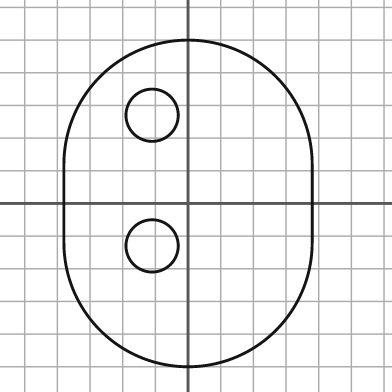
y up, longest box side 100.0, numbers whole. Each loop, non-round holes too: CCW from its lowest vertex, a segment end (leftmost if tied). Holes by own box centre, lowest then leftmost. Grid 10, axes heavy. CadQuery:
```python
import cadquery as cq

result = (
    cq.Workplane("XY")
    .moveTo(-38.0, -12.0)
    .threePointArc((0.0, -50.0), (38.0, -12.0))
    .lineTo(38.0, 12.0)
    .threePointArc((0.0, 50.0), (-38.0, 12.0))
    .close()
    .moveTo(-11.0, -13.0)
    .circle(8.0)
    .moveTo(-11.0, 27.0)
    .circle(8.0)
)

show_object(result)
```